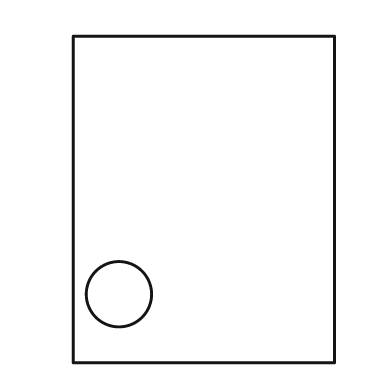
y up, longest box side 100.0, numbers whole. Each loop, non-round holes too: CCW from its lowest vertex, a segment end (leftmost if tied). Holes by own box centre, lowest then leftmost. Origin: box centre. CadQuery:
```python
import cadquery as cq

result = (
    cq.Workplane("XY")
    .moveTo(-40.0, -50.0)
    .lineTo(40.0, -50.0)
    .lineTo(40.0, 50.0)
    .lineTo(-40.0, 50.0)
    .close()
    .moveTo(-26.0, -29.0)
    .circle(10.0)
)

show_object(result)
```